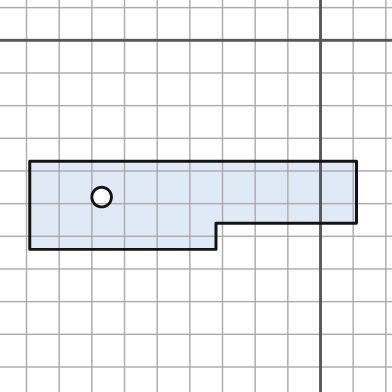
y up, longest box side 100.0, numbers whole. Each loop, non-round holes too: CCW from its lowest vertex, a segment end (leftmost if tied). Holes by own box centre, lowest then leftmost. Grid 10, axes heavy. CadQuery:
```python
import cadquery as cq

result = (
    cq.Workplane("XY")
    .moveTo(-89.0, -64.0)
    .lineTo(-32.0, -64.0)
    .lineTo(-32.0, -56.0)
    .lineTo(11.0, -56.0)
    .lineTo(11.0, -37.0)
    .lineTo(-89.0, -37.0)
    .close()
    .moveTo(-67.0, -48.0)
    .circle(3.0)
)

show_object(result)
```